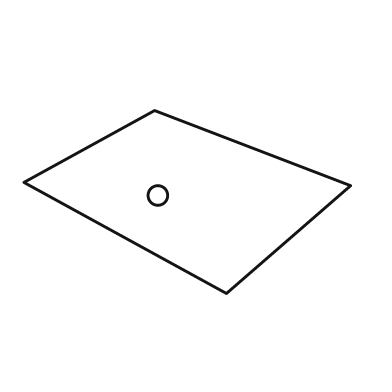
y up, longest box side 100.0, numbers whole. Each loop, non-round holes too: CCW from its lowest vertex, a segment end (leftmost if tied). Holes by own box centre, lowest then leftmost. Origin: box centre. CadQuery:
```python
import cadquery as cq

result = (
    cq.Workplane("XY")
    .moveTo(12.0, -28.0)
    .lineTo(50.0, 5.0)
    .lineTo(-10.0, 28.0)
    .lineTo(-50.0, 6.0)
    .close()
    .moveTo(-9.0, 2.0)
    .circle(3.0)
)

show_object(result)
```